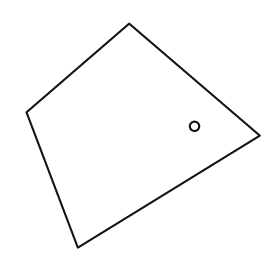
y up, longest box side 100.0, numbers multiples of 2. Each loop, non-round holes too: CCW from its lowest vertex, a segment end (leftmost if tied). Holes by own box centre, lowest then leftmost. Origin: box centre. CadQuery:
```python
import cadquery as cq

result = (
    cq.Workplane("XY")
    .moveTo(-28.0, -48.0)
    .lineTo(50.0, 0.0)
    .lineTo(-6.0, 48.0)
    .lineTo(-50.0, 10.0)
    .close()
    .moveTo(22.0, 4.0)
    .circle(2.0)
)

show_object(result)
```